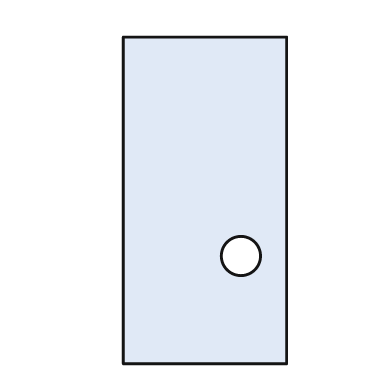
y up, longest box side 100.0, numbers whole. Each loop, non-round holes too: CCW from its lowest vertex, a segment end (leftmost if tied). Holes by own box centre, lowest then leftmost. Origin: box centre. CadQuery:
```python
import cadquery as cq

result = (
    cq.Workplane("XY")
    .moveTo(-25.0, -50.0)
    .lineTo(25.0, -50.0)
    .lineTo(25.0, 50.0)
    .lineTo(-25.0, 50.0)
    .close()
    .moveTo(11.0, -17.0)
    .circle(6.0)
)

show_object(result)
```